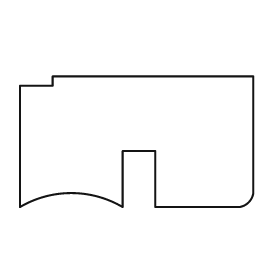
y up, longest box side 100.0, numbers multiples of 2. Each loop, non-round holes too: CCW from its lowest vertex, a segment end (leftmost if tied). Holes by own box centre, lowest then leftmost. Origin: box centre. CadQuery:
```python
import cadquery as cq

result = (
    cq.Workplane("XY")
    .moveTo(-50.0, -28.0)
    .threePointArc((-28.0, -22.0), (-6.0, -28.0))
    .lineTo(-6.0, -4.0)
    .lineTo(8.0, -4.0)
    .lineTo(8.0, -28.0)
    .lineTo(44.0, -28.0)
    .threePointArc((48.0, -26.0), (50.0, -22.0))
    .lineTo(50.0, 28.0)
    .lineTo(-36.0, 28.0)
    .lineTo(-36.0, 24.0)
    .lineTo(-50.0, 24.0)
    .close()
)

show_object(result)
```